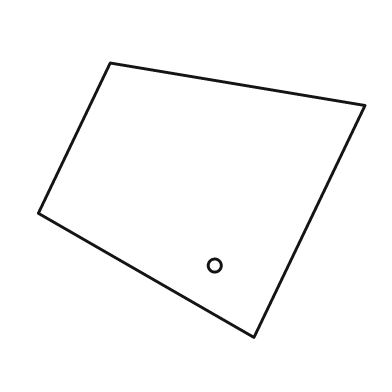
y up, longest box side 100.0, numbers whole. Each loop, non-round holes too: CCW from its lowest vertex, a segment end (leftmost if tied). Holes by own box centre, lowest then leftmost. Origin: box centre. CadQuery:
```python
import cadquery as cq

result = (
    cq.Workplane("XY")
    .moveTo(16.0, -42.0)
    .lineTo(50.0, 29.0)
    .lineTo(-28.0, 42.0)
    .lineTo(-50.0, -4.0)
    .close()
    .moveTo(4.0, -20.0)
    .circle(2.0)
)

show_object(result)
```